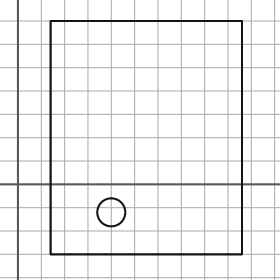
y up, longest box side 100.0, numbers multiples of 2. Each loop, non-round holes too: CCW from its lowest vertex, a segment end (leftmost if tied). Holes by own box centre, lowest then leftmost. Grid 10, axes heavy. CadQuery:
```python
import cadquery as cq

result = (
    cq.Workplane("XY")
    .moveTo(14.0, -30.0)
    .lineTo(96.0, -30.0)
    .lineTo(96.0, 70.0)
    .lineTo(14.0, 70.0)
    .close()
    .moveTo(40.0, -12.0)
    .circle(6.0)
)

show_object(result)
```